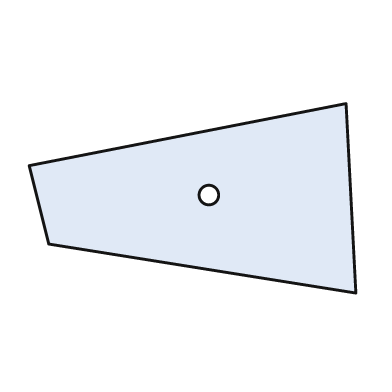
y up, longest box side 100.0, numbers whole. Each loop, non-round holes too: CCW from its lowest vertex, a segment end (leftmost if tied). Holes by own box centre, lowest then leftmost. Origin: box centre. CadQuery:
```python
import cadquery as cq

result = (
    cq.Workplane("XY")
    .moveTo(50.0, -29.0)
    .lineTo(47.0, 29.0)
    .lineTo(-50.0, 10.0)
    .lineTo(-44.0, -14.0)
    .close()
    .moveTo(5.0, 1.0)
    .circle(3.0)
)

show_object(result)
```